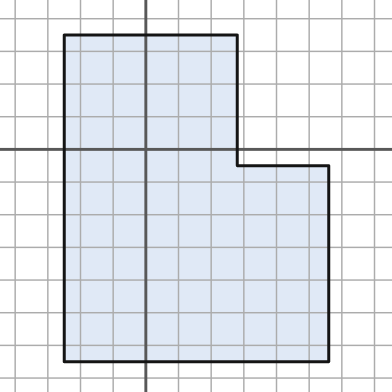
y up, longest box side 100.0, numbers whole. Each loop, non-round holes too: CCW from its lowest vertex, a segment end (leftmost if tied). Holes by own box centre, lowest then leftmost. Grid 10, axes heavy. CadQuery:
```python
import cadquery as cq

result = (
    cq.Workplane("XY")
    .moveTo(-25.0, -65.0)
    .lineTo(56.0, -65.0)
    .lineTo(56.0, -5.0)
    .lineTo(28.0, -5.0)
    .lineTo(28.0, 35.0)
    .lineTo(-25.0, 35.0)
    .close()
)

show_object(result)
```